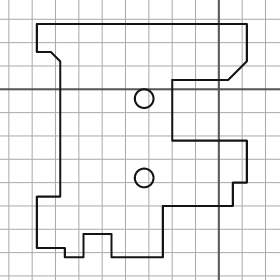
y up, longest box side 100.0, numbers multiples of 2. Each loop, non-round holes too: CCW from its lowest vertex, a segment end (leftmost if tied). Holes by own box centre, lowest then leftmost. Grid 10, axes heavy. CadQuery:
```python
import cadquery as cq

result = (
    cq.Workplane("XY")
    .moveTo(-66.0, -72.0)
    .lineTo(-58.0, -72.0)
    .lineTo(-58.0, -62.0)
    .lineTo(-46.0, -62.0)
    .lineTo(-46.0, -72.0)
    .lineTo(-24.0, -72.0)
    .lineTo(-24.0, -50.0)
    .lineTo(6.0, -50.0)
    .lineTo(6.0, -40.0)
    .lineTo(12.0, -40.0)
    .lineTo(12.0, -22.0)
    .lineTo(-20.0, -22.0)
    .lineTo(-20.0, 4.0)
    .lineTo(4.0, 4.0)
    .lineTo(12.0, 12.0)
    .lineTo(12.0, 28.0)
    .lineTo(-78.0, 28.0)
    .lineTo(-78.0, 16.0)
    .lineTo(-72.0, 16.0)
    .lineTo(-68.0, 12.0)
    .lineTo(-68.0, -46.0)
    .lineTo(-78.0, -46.0)
    .lineTo(-78.0, -68.0)
    .lineTo(-66.0, -68.0)
    .close()
    .moveTo(-32.0, -38.0)
    .circle(4.0)
    .moveTo(-32.0, -4.0)
    .circle(4.0)
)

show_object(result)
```